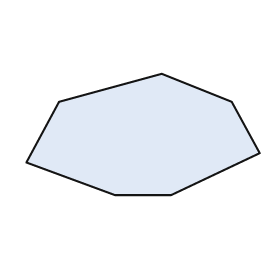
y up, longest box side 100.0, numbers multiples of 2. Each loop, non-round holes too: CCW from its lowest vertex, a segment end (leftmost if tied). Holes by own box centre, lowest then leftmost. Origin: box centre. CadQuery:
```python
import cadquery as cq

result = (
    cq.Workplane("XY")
    .moveTo(-12.0, -26.0)
    .lineTo(12.0, -26.0)
    .lineTo(50.0, -8.0)
    .lineTo(38.0, 14.0)
    .lineTo(8.0, 26.0)
    .lineTo(-36.0, 14.0)
    .lineTo(-50.0, -12.0)
    .close()
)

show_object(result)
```